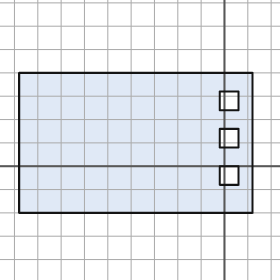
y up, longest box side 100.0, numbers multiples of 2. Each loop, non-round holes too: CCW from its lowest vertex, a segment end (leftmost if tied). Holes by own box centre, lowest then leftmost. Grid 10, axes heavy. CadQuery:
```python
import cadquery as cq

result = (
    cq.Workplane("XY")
    .moveTo(-88.0, -20.0)
    .lineTo(12.0, -20.0)
    .lineTo(12.0, 40.0)
    .lineTo(-88.0, 40.0)
    .close()
    .moveTo(-2.0, -8.0)
    .lineTo(6.0, -8.0)
    .lineTo(6.0, 0.0)
    .lineTo(-2.0, 0.0)
    .close()
    .moveTo(-2.0, 8.0)
    .lineTo(6.0, 8.0)
    .lineTo(6.0, 16.0)
    .lineTo(-2.0, 16.0)
    .close()
    .moveTo(-2.0, 24.0)
    .lineTo(6.0, 24.0)
    .lineTo(6.0, 32.0)
    .lineTo(-2.0, 32.0)
    .close()
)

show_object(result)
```